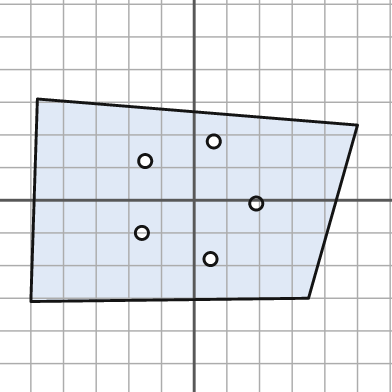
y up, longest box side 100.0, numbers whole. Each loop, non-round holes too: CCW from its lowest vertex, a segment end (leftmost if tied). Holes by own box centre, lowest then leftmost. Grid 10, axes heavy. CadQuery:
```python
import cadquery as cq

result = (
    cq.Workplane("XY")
    .moveTo(-50.0, -31.0)
    .lineTo(35.0, -30.0)
    .lineTo(50.0, 23.0)
    .lineTo(-48.0, 31.0)
    .close()
    .moveTo(5.0, -18.0)
    .circle(2.0)
    .moveTo(-16.0, -10.0)
    .circle(2.0)
    .moveTo(19.0, -1.0)
    .circle(2.0)
    .moveTo(-15.0, 12.0)
    .circle(2.0)
    .moveTo(6.0, 18.0)
    .circle(2.0)
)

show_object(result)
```